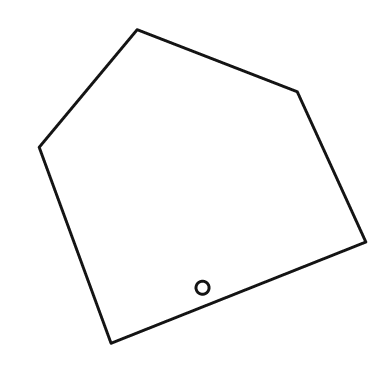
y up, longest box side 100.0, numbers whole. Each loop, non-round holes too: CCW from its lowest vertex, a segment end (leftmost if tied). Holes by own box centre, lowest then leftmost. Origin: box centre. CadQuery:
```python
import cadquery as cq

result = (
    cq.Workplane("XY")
    .moveTo(-28.0, -48.0)
    .lineTo(50.0, -17.0)
    .lineTo(29.0, 29.0)
    .lineTo(-20.0, 48.0)
    .lineTo(-50.0, 12.0)
    .close()
    .moveTo(0.0, -31.0)
    .circle(2.0)
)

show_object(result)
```